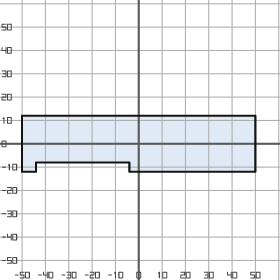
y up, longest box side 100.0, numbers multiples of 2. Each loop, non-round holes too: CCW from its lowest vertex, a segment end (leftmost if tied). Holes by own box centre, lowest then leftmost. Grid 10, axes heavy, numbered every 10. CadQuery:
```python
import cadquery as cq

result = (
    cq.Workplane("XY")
    .moveTo(-50.0, -12.0)
    .lineTo(-44.0, -12.0)
    .lineTo(-44.0, -8.0)
    .lineTo(-4.0, -8.0)
    .lineTo(-4.0, -12.0)
    .lineTo(50.0, -12.0)
    .lineTo(50.0, 12.0)
    .lineTo(-50.0, 12.0)
    .close()
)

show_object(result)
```